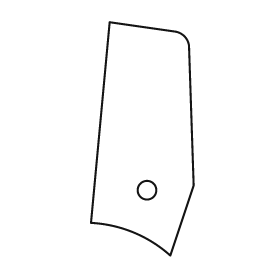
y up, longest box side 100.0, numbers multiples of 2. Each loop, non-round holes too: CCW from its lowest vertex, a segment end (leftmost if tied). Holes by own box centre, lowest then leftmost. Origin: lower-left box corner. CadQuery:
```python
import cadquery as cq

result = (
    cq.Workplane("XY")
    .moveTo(34.0, 0.0)
    .lineTo(44.0, 30.0)
    .lineTo(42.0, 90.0)
    .threePointArc((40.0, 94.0), (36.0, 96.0))
    .lineTo(8.0, 100.0)
    .lineTo(0.0, 14.0)
    .threePointArc((18.0, 10.0), (34.0, 0.0))
    .close()
    .moveTo(24.0, 28.0)
    .circle(4.0)
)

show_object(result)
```